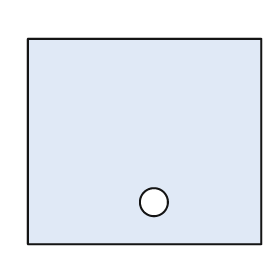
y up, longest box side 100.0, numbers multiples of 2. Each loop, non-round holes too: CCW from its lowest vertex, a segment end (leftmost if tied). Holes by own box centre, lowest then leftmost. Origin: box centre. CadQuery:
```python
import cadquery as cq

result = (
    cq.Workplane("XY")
    .moveTo(-50.0, -44.0)
    .lineTo(50.0, -44.0)
    .lineTo(50.0, 44.0)
    .lineTo(-50.0, 44.0)
    .close()
    .moveTo(4.0, -26.0)
    .circle(6.0)
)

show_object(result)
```